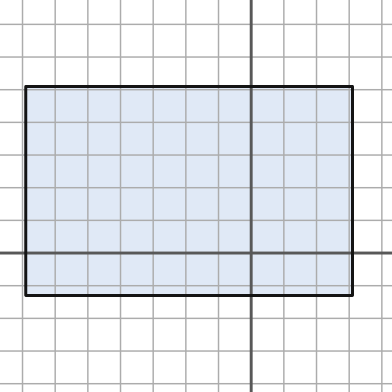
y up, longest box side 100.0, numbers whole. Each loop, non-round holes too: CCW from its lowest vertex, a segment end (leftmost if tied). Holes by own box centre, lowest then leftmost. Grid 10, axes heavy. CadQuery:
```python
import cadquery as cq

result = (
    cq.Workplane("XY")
    .moveTo(-69.0, -13.0)
    .lineTo(31.0, -13.0)
    .lineTo(31.0, 51.0)
    .lineTo(-69.0, 51.0)
    .close()
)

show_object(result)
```